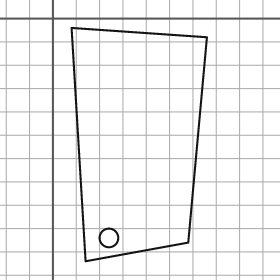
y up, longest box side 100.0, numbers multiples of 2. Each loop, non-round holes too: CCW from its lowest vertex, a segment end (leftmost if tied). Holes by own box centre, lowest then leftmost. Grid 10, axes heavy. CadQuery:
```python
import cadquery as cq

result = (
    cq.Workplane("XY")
    .moveTo(14.0, -104.0)
    .lineTo(58.0, -96.0)
    .lineTo(66.0, -8.0)
    .lineTo(8.0, -4.0)
    .close()
    .moveTo(24.0, -94.0)
    .circle(4.0)
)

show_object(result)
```